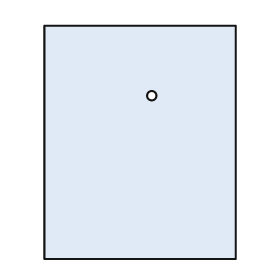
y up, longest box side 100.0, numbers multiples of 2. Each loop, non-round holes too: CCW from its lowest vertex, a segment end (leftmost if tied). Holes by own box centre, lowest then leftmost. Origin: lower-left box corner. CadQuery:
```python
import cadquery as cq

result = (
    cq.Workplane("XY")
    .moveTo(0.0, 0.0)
    .lineTo(82.0, 0.0)
    .lineTo(82.0, 100.0)
    .lineTo(0.0, 100.0)
    .close()
    .moveTo(46.0, 70.0)
    .circle(2.0)
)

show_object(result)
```